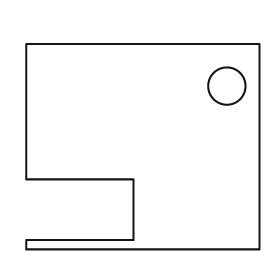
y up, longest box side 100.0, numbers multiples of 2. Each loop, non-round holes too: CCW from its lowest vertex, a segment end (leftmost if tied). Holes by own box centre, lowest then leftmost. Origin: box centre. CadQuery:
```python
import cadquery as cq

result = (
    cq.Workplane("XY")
    .moveTo(-50.0, -44.0)
    .lineTo(50.0, -44.0)
    .lineTo(50.0, 44.0)
    .lineTo(-50.0, 44.0)
    .lineTo(-50.0, -14.0)
    .lineTo(-4.0, -14.0)
    .lineTo(-4.0, -40.0)
    .lineTo(-50.0, -40.0)
    .close()
    .moveTo(36.0, 26.0)
    .circle(8.0)
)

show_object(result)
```